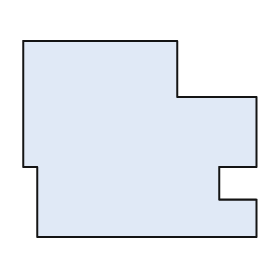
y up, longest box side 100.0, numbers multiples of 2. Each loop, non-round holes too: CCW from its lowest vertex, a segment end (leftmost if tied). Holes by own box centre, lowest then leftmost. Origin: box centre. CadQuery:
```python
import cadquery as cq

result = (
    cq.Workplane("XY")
    .moveTo(-44.0, -42.0)
    .lineTo(50.0, -42.0)
    .lineTo(50.0, -26.0)
    .lineTo(34.0, -26.0)
    .lineTo(34.0, -12.0)
    .lineTo(50.0, -12.0)
    .lineTo(50.0, 18.0)
    .lineTo(16.0, 18.0)
    .lineTo(16.0, 42.0)
    .lineTo(-50.0, 42.0)
    .lineTo(-50.0, -12.0)
    .lineTo(-44.0, -12.0)
    .close()
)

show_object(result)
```